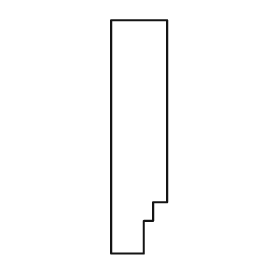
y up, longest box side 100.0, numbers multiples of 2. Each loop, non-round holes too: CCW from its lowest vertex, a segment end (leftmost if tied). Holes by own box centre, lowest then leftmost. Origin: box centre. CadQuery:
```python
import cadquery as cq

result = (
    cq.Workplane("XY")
    .moveTo(-12.0, -50.0)
    .lineTo(2.0, -50.0)
    .lineTo(2.0, -36.0)
    .lineTo(6.0, -36.0)
    .lineTo(6.0, -28.0)
    .lineTo(12.0, -28.0)
    .lineTo(12.0, 50.0)
    .lineTo(-12.0, 50.0)
    .close()
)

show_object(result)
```